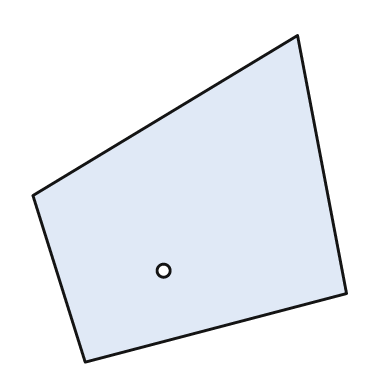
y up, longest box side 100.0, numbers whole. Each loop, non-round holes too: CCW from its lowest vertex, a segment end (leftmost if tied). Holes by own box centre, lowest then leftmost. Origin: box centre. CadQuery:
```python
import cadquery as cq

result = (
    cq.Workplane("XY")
    .moveTo(-32.0, -50.0)
    .lineTo(48.0, -29.0)
    .lineTo(33.0, 50.0)
    .lineTo(-48.0, 1.0)
    .close()
    .moveTo(-8.0, -22.0)
    .circle(2.0)
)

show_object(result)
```